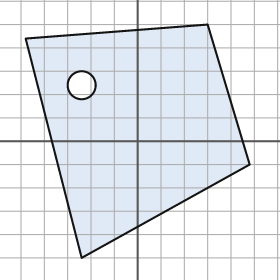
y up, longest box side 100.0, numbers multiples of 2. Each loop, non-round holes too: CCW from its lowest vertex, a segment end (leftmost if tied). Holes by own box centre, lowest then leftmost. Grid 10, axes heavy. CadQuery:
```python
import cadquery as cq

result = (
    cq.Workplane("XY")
    .moveTo(-24.0, -50.0)
    .lineTo(48.0, -10.0)
    .lineTo(30.0, 50.0)
    .lineTo(-48.0, 44.0)
    .close()
    .moveTo(-24.0, 24.0)
    .circle(6.0)
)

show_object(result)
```